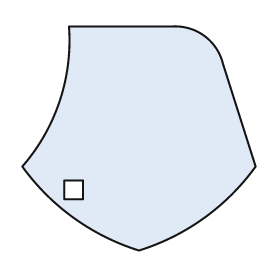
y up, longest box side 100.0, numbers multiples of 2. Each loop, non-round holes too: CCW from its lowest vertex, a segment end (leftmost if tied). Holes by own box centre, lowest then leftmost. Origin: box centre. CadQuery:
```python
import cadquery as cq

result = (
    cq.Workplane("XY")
    .moveTo(0.0, -48.0)
    .threePointArc((28.0, -34.0), (50.0, -12.0))
    .lineTo(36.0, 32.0)
    .threePointArc((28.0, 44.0), (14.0, 48.0))
    .lineTo(-30.0, 48.0)
    .threePointArc((-34.0, 16.0), (-50.0, -12.0))
    .threePointArc((-28.0, -34.0), (0.0, -48.0))
    .close()
    .moveTo(-32.0, -26.0)
    .lineTo(-24.0, -26.0)
    .lineTo(-24.0, -18.0)
    .lineTo(-32.0, -18.0)
    .close()
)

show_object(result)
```